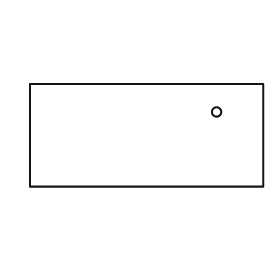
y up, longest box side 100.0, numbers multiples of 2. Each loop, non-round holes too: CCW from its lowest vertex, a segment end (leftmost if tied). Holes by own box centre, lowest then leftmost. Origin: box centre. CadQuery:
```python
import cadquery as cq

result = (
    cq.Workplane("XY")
    .moveTo(-50.0, -22.0)
    .lineTo(50.0, -22.0)
    .lineTo(50.0, 22.0)
    .lineTo(-50.0, 22.0)
    .close()
    .moveTo(30.0, 10.0)
    .circle(2.0)
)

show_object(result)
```